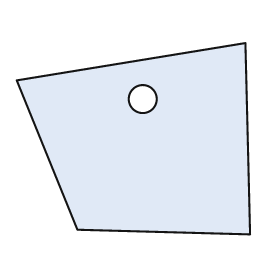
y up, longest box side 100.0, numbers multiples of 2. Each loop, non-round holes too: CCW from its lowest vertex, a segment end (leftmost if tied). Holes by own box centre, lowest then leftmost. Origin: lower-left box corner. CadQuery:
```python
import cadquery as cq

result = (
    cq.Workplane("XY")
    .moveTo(100.0, 0.0)
    .lineTo(98.0, 82.0)
    .lineTo(0.0, 66.0)
    .lineTo(26.0, 2.0)
    .close()
    .moveTo(54.0, 58.0)
    .circle(6.0)
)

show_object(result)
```